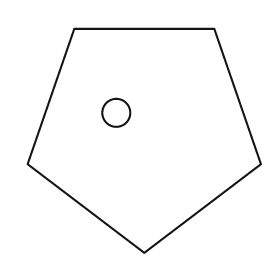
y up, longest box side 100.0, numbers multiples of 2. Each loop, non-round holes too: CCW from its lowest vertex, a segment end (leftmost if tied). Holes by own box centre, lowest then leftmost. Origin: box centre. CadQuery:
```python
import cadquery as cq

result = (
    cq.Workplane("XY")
    .moveTo(0.0, -48.0)
    .lineTo(50.0, -10.0)
    .lineTo(30.0, 48.0)
    .lineTo(-30.0, 48.0)
    .lineTo(-50.0, -10.0)
    .close()
    .moveTo(-12.0, 12.0)
    .circle(6.0)
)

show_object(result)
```